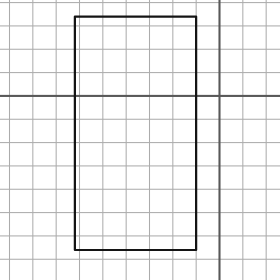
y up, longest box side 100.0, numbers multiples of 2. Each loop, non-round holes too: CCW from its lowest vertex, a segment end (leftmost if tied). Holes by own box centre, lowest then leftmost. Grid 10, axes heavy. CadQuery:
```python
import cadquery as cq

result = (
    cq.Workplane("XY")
    .moveTo(-62.0, -66.0)
    .lineTo(-10.0, -66.0)
    .lineTo(-10.0, 34.0)
    .lineTo(-62.0, 34.0)
    .close()
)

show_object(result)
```